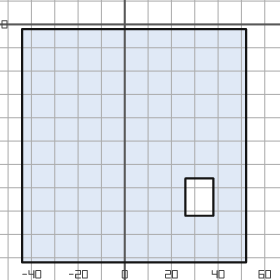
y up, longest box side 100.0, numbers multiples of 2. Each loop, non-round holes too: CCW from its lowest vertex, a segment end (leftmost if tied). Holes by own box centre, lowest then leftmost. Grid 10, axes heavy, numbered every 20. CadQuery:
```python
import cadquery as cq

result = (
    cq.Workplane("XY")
    .moveTo(-44.0, -102.0)
    .lineTo(52.0, -102.0)
    .lineTo(52.0, -2.0)
    .lineTo(-44.0, -2.0)
    .close()
    .moveTo(26.0, -82.0)
    .lineTo(38.0, -82.0)
    .lineTo(38.0, -66.0)
    .lineTo(26.0, -66.0)
    .close()
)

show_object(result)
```